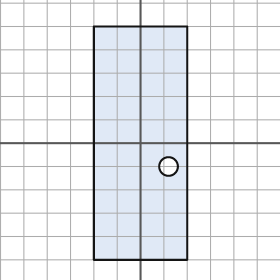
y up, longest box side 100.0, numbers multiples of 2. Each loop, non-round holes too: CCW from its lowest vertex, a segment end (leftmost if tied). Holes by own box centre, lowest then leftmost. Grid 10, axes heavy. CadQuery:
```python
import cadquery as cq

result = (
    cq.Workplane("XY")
    .moveTo(-20.0, -50.0)
    .lineTo(20.0, -50.0)
    .lineTo(20.0, 50.0)
    .lineTo(-20.0, 50.0)
    .close()
    .moveTo(12.0, -10.0)
    .circle(4.0)
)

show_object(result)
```